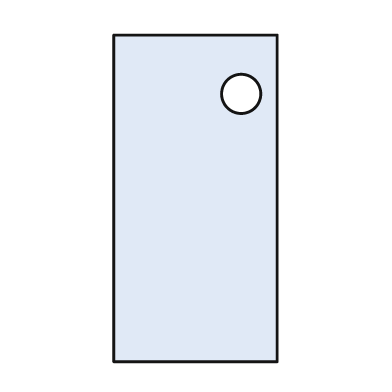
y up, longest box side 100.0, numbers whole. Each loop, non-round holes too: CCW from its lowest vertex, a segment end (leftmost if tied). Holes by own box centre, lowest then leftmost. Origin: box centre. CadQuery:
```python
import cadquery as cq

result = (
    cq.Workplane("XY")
    .moveTo(-25.0, -50.0)
    .lineTo(25.0, -50.0)
    .lineTo(25.0, 50.0)
    .lineTo(-25.0, 50.0)
    .close()
    .moveTo(14.0, 32.0)
    .circle(6.0)
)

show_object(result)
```